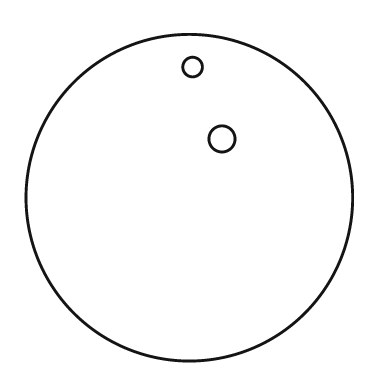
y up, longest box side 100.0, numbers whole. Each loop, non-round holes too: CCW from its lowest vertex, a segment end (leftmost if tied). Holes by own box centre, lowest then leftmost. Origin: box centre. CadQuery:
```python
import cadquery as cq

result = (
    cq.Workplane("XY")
    .moveTo(0.0, 0.0)
    .circle(50.0)
    .moveTo(10.0, 18.0)
    .circle(4.0)
    .moveTo(1.0, 40.0)
    .circle(3.0)
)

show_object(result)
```